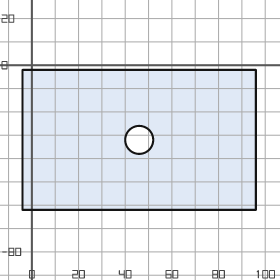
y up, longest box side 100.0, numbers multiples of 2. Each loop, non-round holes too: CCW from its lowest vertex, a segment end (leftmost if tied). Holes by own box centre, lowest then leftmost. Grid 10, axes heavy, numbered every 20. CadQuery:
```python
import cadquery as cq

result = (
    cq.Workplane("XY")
    .moveTo(-4.0, -62.0)
    .lineTo(96.0, -62.0)
    .lineTo(96.0, -2.0)
    .lineTo(-4.0, -2.0)
    .close()
    .moveTo(46.0, -32.0)
    .circle(6.0)
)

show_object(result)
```